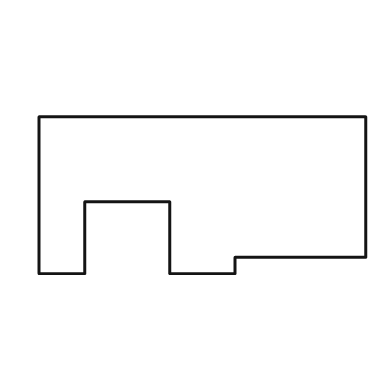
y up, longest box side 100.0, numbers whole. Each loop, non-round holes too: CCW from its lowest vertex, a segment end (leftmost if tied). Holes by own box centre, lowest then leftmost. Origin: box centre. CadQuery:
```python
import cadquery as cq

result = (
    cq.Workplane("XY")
    .moveTo(-50.0, -24.0)
    .lineTo(-36.0, -24.0)
    .lineTo(-36.0, -2.0)
    .lineTo(-10.0, -2.0)
    .lineTo(-10.0, -24.0)
    .lineTo(10.0, -24.0)
    .lineTo(10.0, -19.0)
    .lineTo(50.0, -19.0)
    .lineTo(50.0, 24.0)
    .lineTo(-50.0, 24.0)
    .close()
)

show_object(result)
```